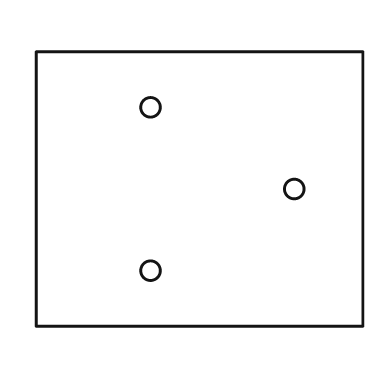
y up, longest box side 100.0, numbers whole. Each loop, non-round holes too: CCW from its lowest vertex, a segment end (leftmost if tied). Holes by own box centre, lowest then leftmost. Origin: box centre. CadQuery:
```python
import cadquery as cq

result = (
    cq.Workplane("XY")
    .moveTo(-50.0, -42.0)
    .lineTo(50.0, -42.0)
    .lineTo(50.0, 42.0)
    .lineTo(-50.0, 42.0)
    .close()
    .moveTo(-15.0, -25.0)
    .circle(3.0)
    .moveTo(29.0, 0.0)
    .circle(3.0)
    .moveTo(-15.0, 25.0)
    .circle(3.0)
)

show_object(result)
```